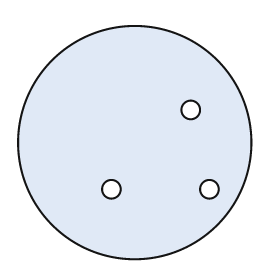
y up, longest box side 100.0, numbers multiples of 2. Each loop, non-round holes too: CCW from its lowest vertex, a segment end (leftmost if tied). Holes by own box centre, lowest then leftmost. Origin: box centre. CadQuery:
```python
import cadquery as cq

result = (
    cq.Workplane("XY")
    .moveTo(0.0, 0.0)
    .circle(50.0)
    .moveTo(-10.0, -20.0)
    .circle(4.0)
    .moveTo(32.0, -20.0)
    .circle(4.0)
    .moveTo(24.0, 14.0)
    .circle(4.0)
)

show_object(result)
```